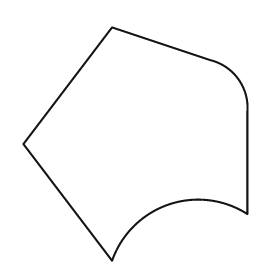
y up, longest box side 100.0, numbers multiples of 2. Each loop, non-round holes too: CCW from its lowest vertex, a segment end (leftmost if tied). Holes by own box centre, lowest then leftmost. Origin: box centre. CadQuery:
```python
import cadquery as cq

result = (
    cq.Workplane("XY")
    .moveTo(-10.0, -50.0)
    .threePointArc((14.0, -26.0), (48.0, -30.0))
    .lineTo(48.0, 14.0)
    .threePointArc((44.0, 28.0), (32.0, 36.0))
    .lineTo(-10.0, 50.0)
    .lineTo(-48.0, 0.0)
    .close()
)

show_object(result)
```